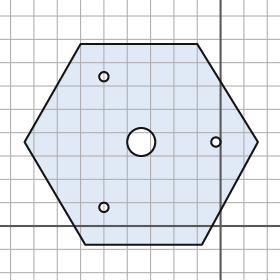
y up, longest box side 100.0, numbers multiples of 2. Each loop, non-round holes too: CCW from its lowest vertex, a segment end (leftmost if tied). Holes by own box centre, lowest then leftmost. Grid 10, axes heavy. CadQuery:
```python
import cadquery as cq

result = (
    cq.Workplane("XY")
    .moveTo(-58.0, -8.0)
    .lineTo(-8.0, -8.0)
    .lineTo(16.0, 36.0)
    .lineTo(-10.0, 78.0)
    .lineTo(-60.0, 78.0)
    .lineTo(-84.0, 36.0)
    .close()
    .moveTo(-50.0, 8.0)
    .circle(2.0)
    .moveTo(-34.0, 36.0)
    .circle(6.0)
    .moveTo(-2.0, 36.0)
    .circle(2.0)
    .moveTo(-50.0, 64.0)
    .circle(2.0)
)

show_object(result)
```